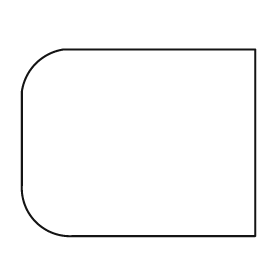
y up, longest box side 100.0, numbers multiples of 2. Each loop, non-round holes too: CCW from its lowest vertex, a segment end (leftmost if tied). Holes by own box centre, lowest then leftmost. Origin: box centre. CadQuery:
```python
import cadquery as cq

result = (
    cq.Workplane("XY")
    .moveTo(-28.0, -40.0)
    .lineTo(50.0, -40.0)
    .lineTo(50.0, 40.0)
    .lineTo(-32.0, 40.0)
    .threePointArc((-44.0, 34.0), (-50.0, 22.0))
    .lineTo(-50.0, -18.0)
    .threePointArc((-44.0, -34.0), (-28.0, -40.0))
    .close()
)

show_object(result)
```